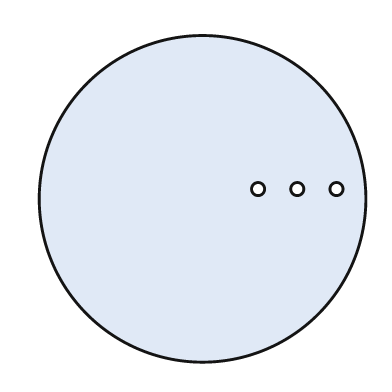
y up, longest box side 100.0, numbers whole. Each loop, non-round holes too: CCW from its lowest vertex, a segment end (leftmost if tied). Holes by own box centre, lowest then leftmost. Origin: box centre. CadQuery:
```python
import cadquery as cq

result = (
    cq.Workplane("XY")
    .moveTo(0.0, 0.0)
    .circle(50.0)
    .moveTo(17.0, 3.0)
    .circle(2.0)
    .moveTo(29.0, 3.0)
    .circle(2.0)
    .moveTo(41.0, 3.0)
    .circle(2.0)
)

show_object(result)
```